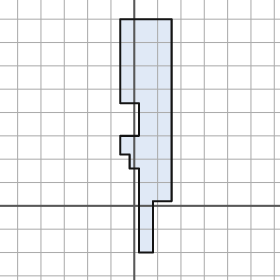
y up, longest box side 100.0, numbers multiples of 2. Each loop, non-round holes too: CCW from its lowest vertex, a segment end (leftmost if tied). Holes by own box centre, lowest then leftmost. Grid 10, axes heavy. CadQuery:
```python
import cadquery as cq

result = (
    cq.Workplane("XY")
    .moveTo(2.0, -20.0)
    .lineTo(8.0, -20.0)
    .lineTo(8.0, 2.0)
    .lineTo(16.0, 2.0)
    .lineTo(16.0, 80.0)
    .lineTo(-6.0, 80.0)
    .lineTo(-6.0, 44.0)
    .lineTo(2.0, 44.0)
    .lineTo(2.0, 30.0)
    .lineTo(-6.0, 30.0)
    .lineTo(-6.0, 22.0)
    .lineTo(-2.0, 22.0)
    .lineTo(-2.0, 16.0)
    .lineTo(2.0, 16.0)
    .close()
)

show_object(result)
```